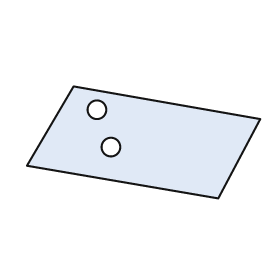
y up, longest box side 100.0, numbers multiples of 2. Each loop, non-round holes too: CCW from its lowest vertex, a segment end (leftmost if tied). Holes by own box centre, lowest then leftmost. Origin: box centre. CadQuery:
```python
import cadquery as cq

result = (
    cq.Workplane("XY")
    .moveTo(32.0, -24.0)
    .lineTo(50.0, 10.0)
    .lineTo(-30.0, 24.0)
    .lineTo(-50.0, -10.0)
    .close()
    .moveTo(-14.0, -2.0)
    .circle(4.0)
    .moveTo(-20.0, 14.0)
    .circle(4.0)
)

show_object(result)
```